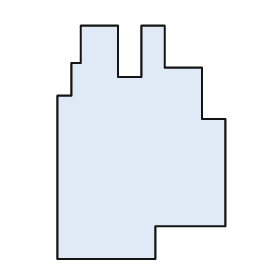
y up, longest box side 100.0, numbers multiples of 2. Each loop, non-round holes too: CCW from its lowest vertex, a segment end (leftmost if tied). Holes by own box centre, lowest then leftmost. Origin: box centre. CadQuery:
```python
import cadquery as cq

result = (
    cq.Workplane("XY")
    .moveTo(-36.0, -50.0)
    .lineTo(6.0, -50.0)
    .lineTo(6.0, -36.0)
    .lineTo(36.0, -36.0)
    .lineTo(36.0, 10.0)
    .lineTo(26.0, 10.0)
    .lineTo(26.0, 32.0)
    .lineTo(10.0, 32.0)
    .lineTo(10.0, 50.0)
    .lineTo(0.0, 50.0)
    .lineTo(0.0, 28.0)
    .lineTo(-10.0, 28.0)
    .lineTo(-10.0, 50.0)
    .lineTo(-26.0, 50.0)
    .lineTo(-26.0, 34.0)
    .lineTo(-30.0, 34.0)
    .lineTo(-30.0, 20.0)
    .lineTo(-36.0, 20.0)
    .close()
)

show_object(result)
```